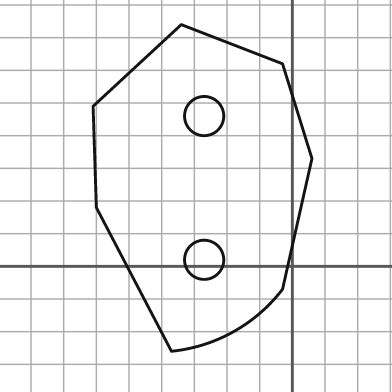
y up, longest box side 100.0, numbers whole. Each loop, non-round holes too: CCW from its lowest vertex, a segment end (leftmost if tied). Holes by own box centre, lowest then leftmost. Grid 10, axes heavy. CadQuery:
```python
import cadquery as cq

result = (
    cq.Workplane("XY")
    .moveTo(-37.0, -26.0)
    .threePointArc((-18.0, -20.0), (-3.0, -7.0))
    .lineTo(6.0, 33.0)
    .lineTo(-3.0, 62.0)
    .lineTo(-34.0, 74.0)
    .lineTo(-61.0, 49.0)
    .lineTo(-60.0, 18.0)
    .close()
    .moveTo(-27.0, 2.0)
    .circle(6.0)
    .moveTo(-27.0, 46.0)
    .circle(6.0)
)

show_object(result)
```